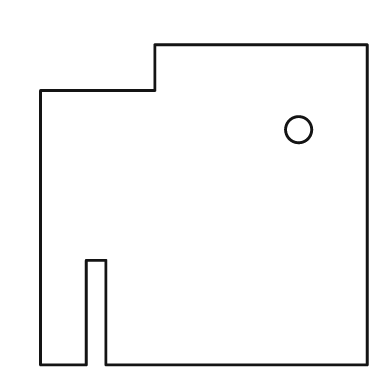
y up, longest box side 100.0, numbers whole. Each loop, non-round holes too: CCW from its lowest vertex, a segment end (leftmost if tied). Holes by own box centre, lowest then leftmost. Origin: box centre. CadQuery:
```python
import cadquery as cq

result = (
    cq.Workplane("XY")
    .moveTo(-50.0, -49.0)
    .lineTo(-36.0, -49.0)
    .lineTo(-36.0, -17.0)
    .lineTo(-30.0, -17.0)
    .lineTo(-30.0, -49.0)
    .lineTo(50.0, -49.0)
    .lineTo(50.0, 49.0)
    .lineTo(-15.0, 49.0)
    .lineTo(-15.0, 35.0)
    .lineTo(-50.0, 35.0)
    .close()
    .moveTo(29.0, 23.0)
    .circle(4.0)
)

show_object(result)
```